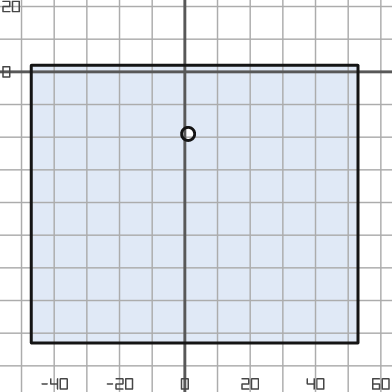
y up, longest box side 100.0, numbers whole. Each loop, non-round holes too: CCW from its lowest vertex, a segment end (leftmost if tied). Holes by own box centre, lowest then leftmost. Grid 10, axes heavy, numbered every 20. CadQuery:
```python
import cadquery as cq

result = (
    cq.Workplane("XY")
    .moveTo(-47.0, -83.0)
    .lineTo(53.0, -83.0)
    .lineTo(53.0, 2.0)
    .lineTo(-47.0, 2.0)
    .close()
    .moveTo(1.0, -19.0)
    .circle(2.0)
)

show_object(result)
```